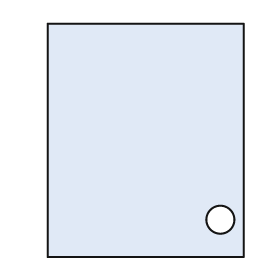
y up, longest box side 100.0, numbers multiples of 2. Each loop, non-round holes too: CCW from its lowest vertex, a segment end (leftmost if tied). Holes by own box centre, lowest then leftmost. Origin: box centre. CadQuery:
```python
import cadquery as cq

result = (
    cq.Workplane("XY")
    .moveTo(-42.0, -50.0)
    .lineTo(42.0, -50.0)
    .lineTo(42.0, 50.0)
    .lineTo(-42.0, 50.0)
    .close()
    .moveTo(32.0, -34.0)
    .circle(6.0)
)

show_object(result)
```